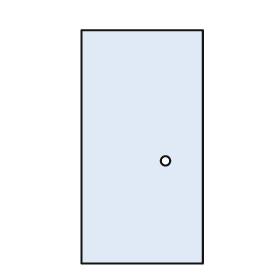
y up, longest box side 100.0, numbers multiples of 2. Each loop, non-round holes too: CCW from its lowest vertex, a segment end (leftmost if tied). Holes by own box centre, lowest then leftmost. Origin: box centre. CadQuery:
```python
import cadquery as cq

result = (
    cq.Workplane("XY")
    .moveTo(-26.0, -50.0)
    .lineTo(26.0, -50.0)
    .lineTo(26.0, 50.0)
    .lineTo(-26.0, 50.0)
    .close()
    .moveTo(10.0, -6.0)
    .circle(2.0)
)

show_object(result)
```